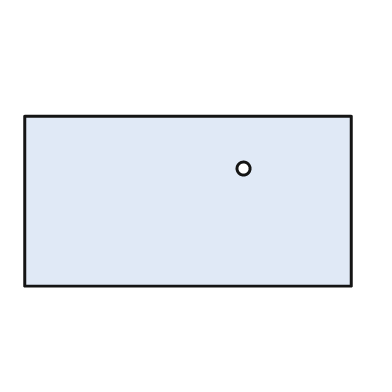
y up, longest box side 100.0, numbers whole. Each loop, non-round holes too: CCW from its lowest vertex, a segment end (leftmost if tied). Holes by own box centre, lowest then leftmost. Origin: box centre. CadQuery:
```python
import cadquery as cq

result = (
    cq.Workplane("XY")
    .moveTo(-50.0, -26.0)
    .lineTo(50.0, -26.0)
    .lineTo(50.0, 26.0)
    .lineTo(-50.0, 26.0)
    .close()
    .moveTo(17.0, 10.0)
    .circle(2.0)
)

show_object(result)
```